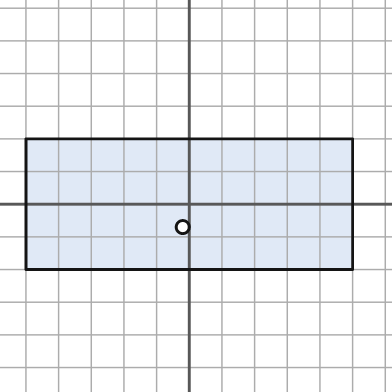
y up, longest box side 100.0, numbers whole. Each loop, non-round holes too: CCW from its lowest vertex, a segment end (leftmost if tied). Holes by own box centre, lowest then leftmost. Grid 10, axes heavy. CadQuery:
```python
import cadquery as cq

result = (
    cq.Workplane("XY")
    .moveTo(-50.0, -20.0)
    .lineTo(50.0, -20.0)
    .lineTo(50.0, 20.0)
    .lineTo(-50.0, 20.0)
    .close()
    .moveTo(-2.0, -7.0)
    .circle(2.0)
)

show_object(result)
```